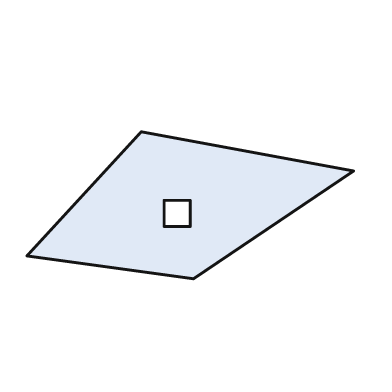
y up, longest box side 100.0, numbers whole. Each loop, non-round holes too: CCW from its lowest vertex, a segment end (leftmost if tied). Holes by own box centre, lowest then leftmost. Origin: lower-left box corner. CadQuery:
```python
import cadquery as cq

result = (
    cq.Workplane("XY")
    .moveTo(51.0, 0.0)
    .lineTo(100.0, 33.0)
    .lineTo(35.0, 45.0)
    .lineTo(0.0, 7.0)
    .close()
    .moveTo(42.0, 16.0)
    .lineTo(50.0, 16.0)
    .lineTo(50.0, 24.0)
    .lineTo(42.0, 24.0)
    .close()
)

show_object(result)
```